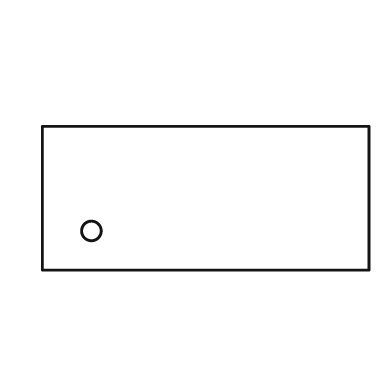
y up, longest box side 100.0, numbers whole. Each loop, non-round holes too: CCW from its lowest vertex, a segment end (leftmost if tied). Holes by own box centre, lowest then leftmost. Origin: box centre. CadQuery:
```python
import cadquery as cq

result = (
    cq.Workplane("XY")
    .moveTo(-50.0, -22.0)
    .lineTo(50.0, -22.0)
    .lineTo(50.0, 22.0)
    .lineTo(-50.0, 22.0)
    .close()
    .moveTo(-35.0, -10.0)
    .circle(3.0)
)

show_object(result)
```